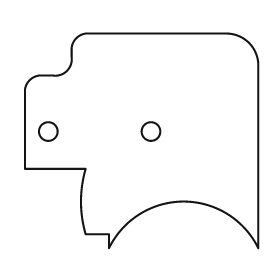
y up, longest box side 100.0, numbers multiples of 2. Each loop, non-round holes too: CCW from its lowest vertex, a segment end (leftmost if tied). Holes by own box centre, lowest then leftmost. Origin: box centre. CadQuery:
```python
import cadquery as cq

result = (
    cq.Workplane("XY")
    .moveTo(-14.0, -46.0)
    .threePointArc((18.0, -26.0), (50.0, -46.0))
    .lineTo(50.0, 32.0)
    .threePointArc((46.0, 42.0), (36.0, 46.0))
    .lineTo(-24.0, 46.0)
    .threePointArc((-28.0, 44.0), (-30.0, 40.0))
    .lineTo(-30.0, 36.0)
    .threePointArc((-32.0, 30.0), (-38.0, 28.0))
    .lineTo(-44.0, 28.0)
    .threePointArc((-48.0, 26.0), (-50.0, 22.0))
    .lineTo(-50.0, -12.0)
    .lineTo(-24.0, -12.0)
    .threePointArc((-26.0, -26.0), (-24.0, -40.0))
    .lineTo(-14.0, -40.0)
    .close()
    .moveTo(-40.0, 4.0)
    .circle(4.0)
    .moveTo(4.0, 4.0)
    .circle(4.0)
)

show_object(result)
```